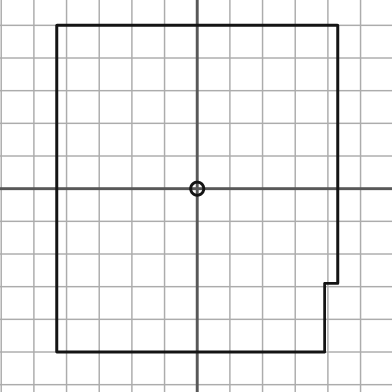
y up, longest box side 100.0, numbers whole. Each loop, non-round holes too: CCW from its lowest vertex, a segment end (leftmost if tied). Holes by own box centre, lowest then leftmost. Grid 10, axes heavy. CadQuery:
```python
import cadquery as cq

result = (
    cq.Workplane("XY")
    .moveTo(-43.0, -50.0)
    .lineTo(39.0, -50.0)
    .lineTo(39.0, -29.0)
    .lineTo(43.0, -29.0)
    .lineTo(43.0, 50.0)
    .lineTo(-43.0, 50.0)
    .close()
    .moveTo(0.0, 0.0)
    .circle(2.0)
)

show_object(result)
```